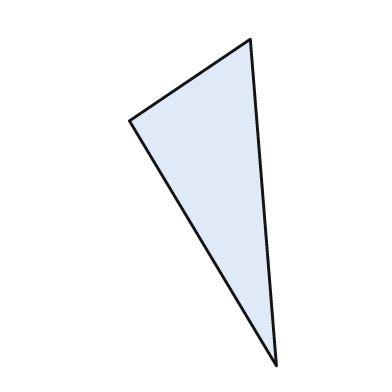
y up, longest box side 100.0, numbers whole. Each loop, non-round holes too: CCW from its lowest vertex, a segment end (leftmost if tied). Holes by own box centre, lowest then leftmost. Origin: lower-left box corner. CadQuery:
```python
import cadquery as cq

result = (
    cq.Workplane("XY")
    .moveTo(45.0, 0.0)
    .lineTo(37.0, 100.0)
    .lineTo(0.0, 75.0)
    .close()
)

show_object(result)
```